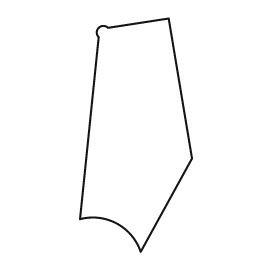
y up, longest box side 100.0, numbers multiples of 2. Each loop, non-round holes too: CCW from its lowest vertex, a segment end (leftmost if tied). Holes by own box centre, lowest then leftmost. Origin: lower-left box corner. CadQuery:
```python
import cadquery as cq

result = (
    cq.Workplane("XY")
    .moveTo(26.0, 0.0)
    .lineTo(48.0, 40.0)
    .lineTo(38.0, 100.0)
    .lineTo(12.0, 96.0)
    .threePointArc((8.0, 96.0), (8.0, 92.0))
    .lineTo(0.0, 14.0)
    .threePointArc((16.0, 12.0), (26.0, 0.0))
    .close()
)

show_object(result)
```